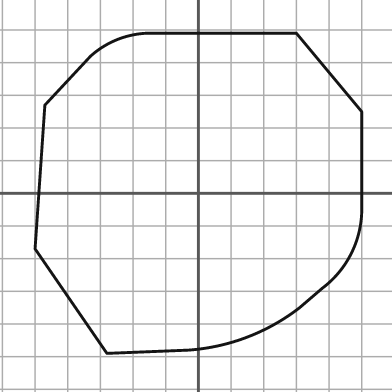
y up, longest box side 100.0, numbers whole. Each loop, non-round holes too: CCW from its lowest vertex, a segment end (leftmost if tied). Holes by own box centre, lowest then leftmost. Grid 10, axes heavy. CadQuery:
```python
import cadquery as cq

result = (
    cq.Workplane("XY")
    .moveTo(-28.0, -49.0)
    .lineTo(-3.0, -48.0)
    .threePointArc((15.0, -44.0), (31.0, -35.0))
    .lineTo(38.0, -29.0)
    .threePointArc((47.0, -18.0), (50.0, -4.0))
    .lineTo(50.0, 25.0)
    .lineTo(30.0, 49.0)
    .lineTo(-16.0, 49.0)
    .threePointArc((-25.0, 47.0), (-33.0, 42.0))
    .lineTo(-47.0, 27.0)
    .lineTo(-50.0, -17.0)
    .close()
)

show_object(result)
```